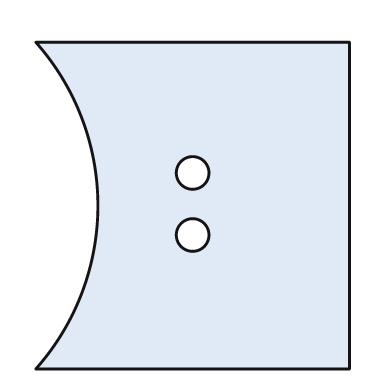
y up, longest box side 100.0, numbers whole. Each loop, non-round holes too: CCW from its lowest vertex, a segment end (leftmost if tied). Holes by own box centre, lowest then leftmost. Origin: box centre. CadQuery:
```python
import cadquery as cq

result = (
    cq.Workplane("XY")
    .moveTo(-48.0, -50.0)
    .lineTo(48.0, -50.0)
    .lineTo(48.0, 50.0)
    .lineTo(-48.0, 50.0)
    .threePointArc((-29.0, 0.0), (-48.0, -50.0))
    .close()
    .moveTo(0.0, -9.0)
    .circle(5.0)
    .moveTo(0.0, 10.0)
    .circle(5.0)
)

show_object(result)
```